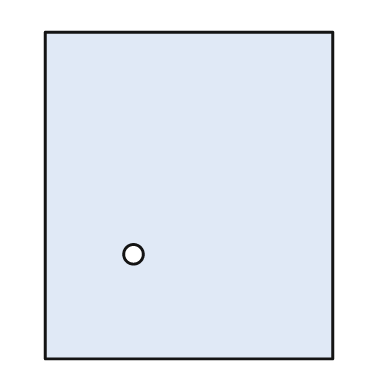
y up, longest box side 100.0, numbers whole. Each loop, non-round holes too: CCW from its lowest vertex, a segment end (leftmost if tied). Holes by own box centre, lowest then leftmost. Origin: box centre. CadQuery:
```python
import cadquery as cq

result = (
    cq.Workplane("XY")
    .moveTo(-44.0, -50.0)
    .lineTo(44.0, -50.0)
    .lineTo(44.0, 50.0)
    .lineTo(-44.0, 50.0)
    .close()
    .moveTo(-17.0, -18.0)
    .circle(3.0)
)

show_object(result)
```